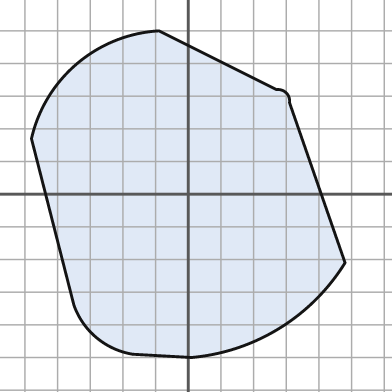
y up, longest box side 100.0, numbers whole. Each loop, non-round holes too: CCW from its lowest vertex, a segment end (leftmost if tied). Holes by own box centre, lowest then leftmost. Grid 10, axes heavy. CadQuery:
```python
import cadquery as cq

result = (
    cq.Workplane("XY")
    .moveTo(1.0, -50.0)
    .threePointArc((28.0, -41.0), (48.0, -21.0))
    .lineTo(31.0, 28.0)
    .threePointArc((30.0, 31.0), (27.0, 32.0))
    .lineTo(-9.0, 50.0)
    .threePointArc((-34.0, 40.0), (-48.0, 17.0))
    .lineTo(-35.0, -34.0)
    .threePointArc((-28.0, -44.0), (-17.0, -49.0))
    .close()
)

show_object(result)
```